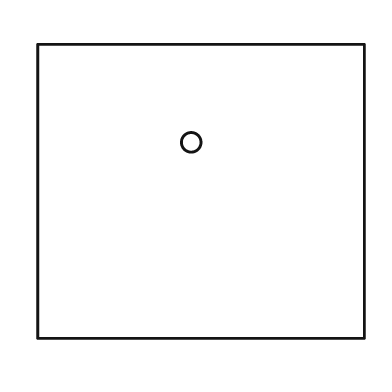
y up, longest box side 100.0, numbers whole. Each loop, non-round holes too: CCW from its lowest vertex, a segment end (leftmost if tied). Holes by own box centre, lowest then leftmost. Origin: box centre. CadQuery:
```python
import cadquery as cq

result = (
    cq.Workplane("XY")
    .moveTo(-50.0, -45.0)
    .lineTo(50.0, -45.0)
    .lineTo(50.0, 45.0)
    .lineTo(-50.0, 45.0)
    .close()
    .moveTo(-3.0, 15.0)
    .circle(3.0)
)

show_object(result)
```